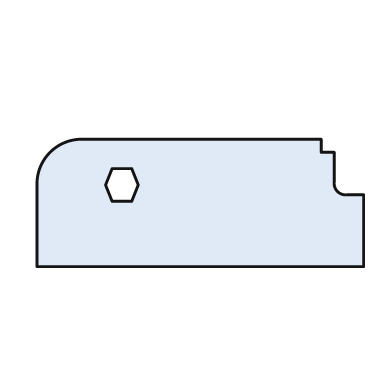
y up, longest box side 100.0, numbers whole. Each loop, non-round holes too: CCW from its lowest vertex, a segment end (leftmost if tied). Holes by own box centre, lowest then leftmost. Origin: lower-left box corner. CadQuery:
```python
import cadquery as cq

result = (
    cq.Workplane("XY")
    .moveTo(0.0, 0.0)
    .lineTo(100.0, 0.0)
    .lineTo(100.0, 22.0)
    .lineTo(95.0, 22.0)
    .threePointArc((92.0, 23.0), (91.0, 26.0))
    .lineTo(91.0, 35.0)
    .lineTo(87.0, 35.0)
    .lineTo(87.0, 39.0)
    .lineTo(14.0, 39.0)
    .threePointArc((4.0, 35.0), (0.0, 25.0))
    .close()
    .moveTo(23.0, 20.0)
    .lineTo(29.0, 20.0)
    .lineTo(31.0, 25.0)
    .lineTo(29.0, 30.0)
    .lineTo(23.0, 30.0)
    .lineTo(21.0, 25.0)
    .close()
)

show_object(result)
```